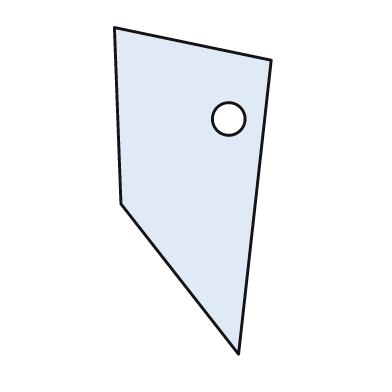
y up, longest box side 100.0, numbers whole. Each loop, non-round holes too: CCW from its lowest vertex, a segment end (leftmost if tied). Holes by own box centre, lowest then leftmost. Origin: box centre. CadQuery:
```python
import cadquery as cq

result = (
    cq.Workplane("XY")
    .moveTo(14.0, -50.0)
    .lineTo(24.0, 40.0)
    .lineTo(-24.0, 50.0)
    .lineTo(-22.0, -4.0)
    .close()
    .moveTo(11.0, 22.0)
    .circle(5.0)
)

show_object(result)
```